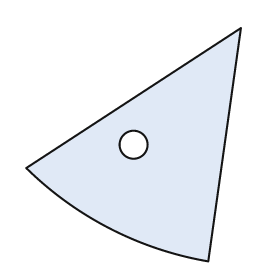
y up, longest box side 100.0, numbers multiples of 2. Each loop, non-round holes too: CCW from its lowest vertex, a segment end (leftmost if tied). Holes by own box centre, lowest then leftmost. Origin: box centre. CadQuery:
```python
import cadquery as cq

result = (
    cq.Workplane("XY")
    .moveTo(32.0, -50.0)
    .lineTo(46.0, 50.0)
    .lineTo(-46.0, -10.0)
    .threePointArc((-10.0, -36.0), (32.0, -50.0))
    .close()
    .moveTo(0.0, 0.0)
    .circle(6.0)
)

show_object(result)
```